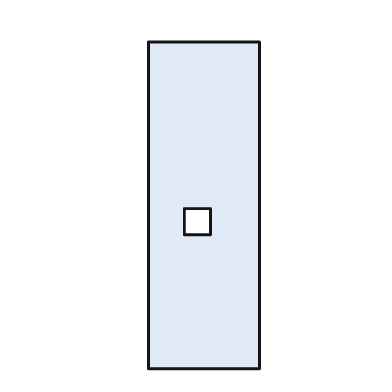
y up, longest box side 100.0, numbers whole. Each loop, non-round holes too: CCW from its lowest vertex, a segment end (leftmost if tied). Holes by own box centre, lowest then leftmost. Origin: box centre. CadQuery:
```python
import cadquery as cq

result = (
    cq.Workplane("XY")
    .moveTo(-17.0, -50.0)
    .lineTo(17.0, -50.0)
    .lineTo(17.0, 50.0)
    .lineTo(-17.0, 50.0)
    .close()
    .moveTo(-6.0, -9.0)
    .lineTo(2.0, -9.0)
    .lineTo(2.0, -1.0)
    .lineTo(-6.0, -1.0)
    .close()
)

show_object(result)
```